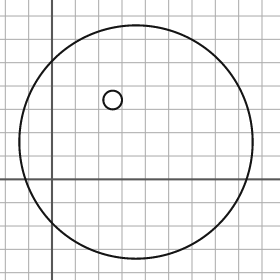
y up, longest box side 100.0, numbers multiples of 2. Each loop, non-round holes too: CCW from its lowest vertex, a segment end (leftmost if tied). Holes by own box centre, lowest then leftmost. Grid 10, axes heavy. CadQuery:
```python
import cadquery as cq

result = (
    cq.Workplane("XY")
    .moveTo(36.0, 16.0)
    .circle(50.0)
    .moveTo(26.0, 34.0)
    .circle(4.0)
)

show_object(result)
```